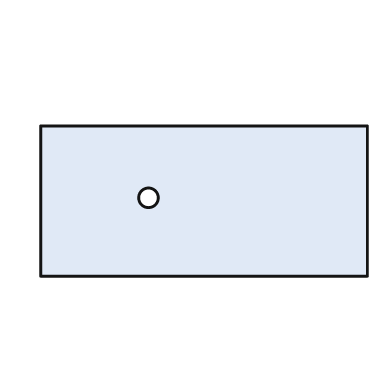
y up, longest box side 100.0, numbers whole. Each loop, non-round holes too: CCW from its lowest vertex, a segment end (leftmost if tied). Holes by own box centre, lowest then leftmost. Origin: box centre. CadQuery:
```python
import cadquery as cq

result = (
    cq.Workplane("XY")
    .moveTo(-50.0, -23.0)
    .lineTo(50.0, -23.0)
    .lineTo(50.0, 23.0)
    .lineTo(-50.0, 23.0)
    .close()
    .moveTo(-17.0, 1.0)
    .circle(3.0)
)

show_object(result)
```